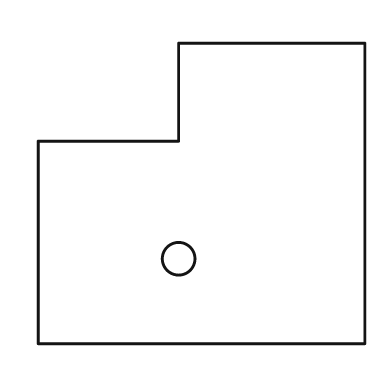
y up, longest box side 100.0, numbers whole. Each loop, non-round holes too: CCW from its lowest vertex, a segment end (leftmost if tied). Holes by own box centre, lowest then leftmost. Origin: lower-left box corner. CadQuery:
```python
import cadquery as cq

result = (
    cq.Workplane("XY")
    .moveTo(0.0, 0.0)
    .lineTo(100.0, 0.0)
    .lineTo(100.0, 92.0)
    .lineTo(43.0, 92.0)
    .lineTo(43.0, 62.0)
    .lineTo(0.0, 62.0)
    .close()
    .moveTo(43.0, 26.0)
    .circle(5.0)
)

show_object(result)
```